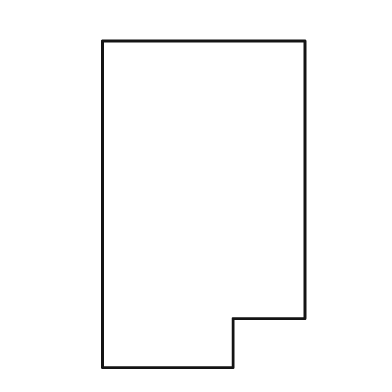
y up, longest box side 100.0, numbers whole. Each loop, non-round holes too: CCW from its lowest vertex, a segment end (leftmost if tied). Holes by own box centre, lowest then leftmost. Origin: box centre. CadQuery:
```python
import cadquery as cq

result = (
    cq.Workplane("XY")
    .moveTo(-31.0, -50.0)
    .lineTo(9.0, -50.0)
    .lineTo(9.0, -35.0)
    .lineTo(31.0, -35.0)
    .lineTo(31.0, 50.0)
    .lineTo(-31.0, 50.0)
    .close()
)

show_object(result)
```